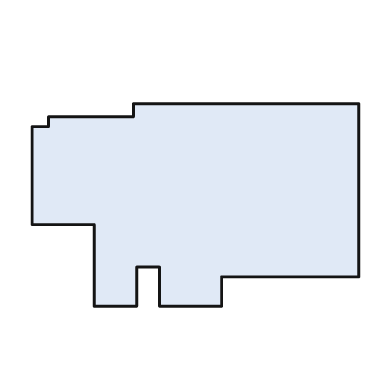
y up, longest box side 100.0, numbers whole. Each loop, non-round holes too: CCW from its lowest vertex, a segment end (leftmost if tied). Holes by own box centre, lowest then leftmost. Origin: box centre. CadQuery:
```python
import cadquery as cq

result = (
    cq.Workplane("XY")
    .moveTo(-31.0, -31.0)
    .lineTo(-18.0, -31.0)
    .lineTo(-18.0, -19.0)
    .lineTo(-11.0, -19.0)
    .lineTo(-11.0, -31.0)
    .lineTo(8.0, -31.0)
    .lineTo(8.0, -22.0)
    .lineTo(50.0, -22.0)
    .lineTo(50.0, 31.0)
    .lineTo(-19.0, 31.0)
    .lineTo(-19.0, 27.0)
    .lineTo(-45.0, 27.0)
    .lineTo(-45.0, 24.0)
    .lineTo(-50.0, 24.0)
    .lineTo(-50.0, -6.0)
    .lineTo(-31.0, -6.0)
    .close()
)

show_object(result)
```